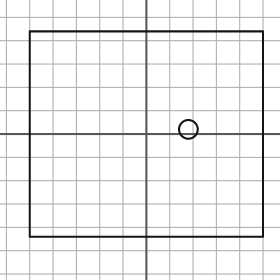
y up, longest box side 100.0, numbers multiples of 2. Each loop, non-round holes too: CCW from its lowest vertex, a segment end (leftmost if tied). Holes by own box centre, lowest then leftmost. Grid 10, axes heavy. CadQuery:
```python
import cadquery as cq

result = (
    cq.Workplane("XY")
    .moveTo(-50.0, -44.0)
    .lineTo(50.0, -44.0)
    .lineTo(50.0, 44.0)
    .lineTo(-50.0, 44.0)
    .close()
    .moveTo(18.0, 2.0)
    .circle(4.0)
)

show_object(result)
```